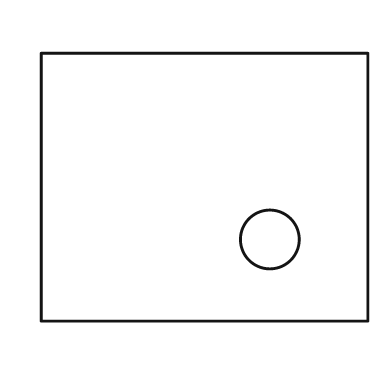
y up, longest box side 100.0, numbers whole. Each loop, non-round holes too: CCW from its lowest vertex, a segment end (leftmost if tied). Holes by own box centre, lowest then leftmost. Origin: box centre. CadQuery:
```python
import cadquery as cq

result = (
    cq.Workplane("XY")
    .moveTo(-50.0, -41.0)
    .lineTo(50.0, -41.0)
    .lineTo(50.0, 41.0)
    .lineTo(-50.0, 41.0)
    .close()
    .moveTo(20.0, -16.0)
    .circle(9.0)
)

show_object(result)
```